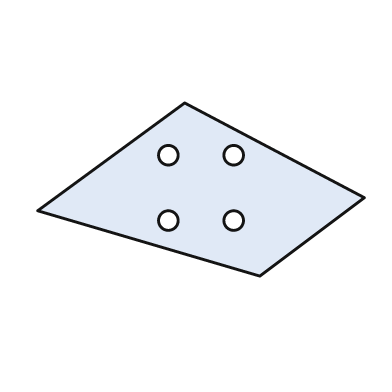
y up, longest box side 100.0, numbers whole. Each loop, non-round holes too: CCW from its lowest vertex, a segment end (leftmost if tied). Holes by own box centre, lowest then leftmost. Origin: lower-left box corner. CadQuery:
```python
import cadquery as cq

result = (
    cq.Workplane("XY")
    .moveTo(68.0, 0.0)
    .lineTo(100.0, 24.0)
    .lineTo(45.0, 53.0)
    .lineTo(0.0, 20.0)
    .close()
    .moveTo(40.0, 17.0)
    .circle(3.0)
    .moveTo(60.0, 17.0)
    .circle(3.0)
    .moveTo(40.0, 37.0)
    .circle(3.0)
    .moveTo(60.0, 37.0)
    .circle(3.0)
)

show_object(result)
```